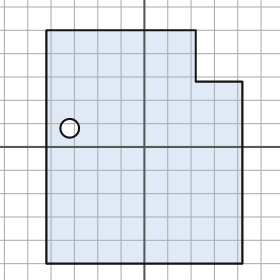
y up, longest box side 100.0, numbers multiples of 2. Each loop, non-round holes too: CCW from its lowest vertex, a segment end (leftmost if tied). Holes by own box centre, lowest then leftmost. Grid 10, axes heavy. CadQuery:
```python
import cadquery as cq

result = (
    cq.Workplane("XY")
    .moveTo(-42.0, -50.0)
    .lineTo(42.0, -50.0)
    .lineTo(42.0, 28.0)
    .lineTo(22.0, 28.0)
    .lineTo(22.0, 50.0)
    .lineTo(-42.0, 50.0)
    .close()
    .moveTo(-32.0, 8.0)
    .circle(4.0)
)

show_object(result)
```